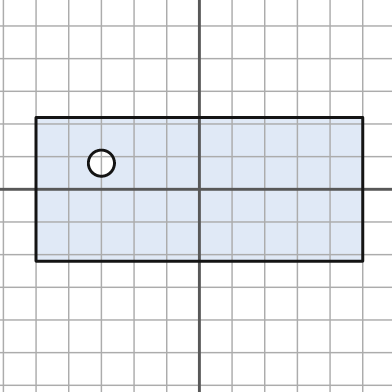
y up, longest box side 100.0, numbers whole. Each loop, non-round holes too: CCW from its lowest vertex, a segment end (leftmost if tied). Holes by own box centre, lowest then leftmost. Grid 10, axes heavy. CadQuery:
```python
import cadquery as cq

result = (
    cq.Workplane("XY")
    .moveTo(-50.0, -22.0)
    .lineTo(50.0, -22.0)
    .lineTo(50.0, 22.0)
    .lineTo(-50.0, 22.0)
    .close()
    .moveTo(-30.0, 8.0)
    .circle(4.0)
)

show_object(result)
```